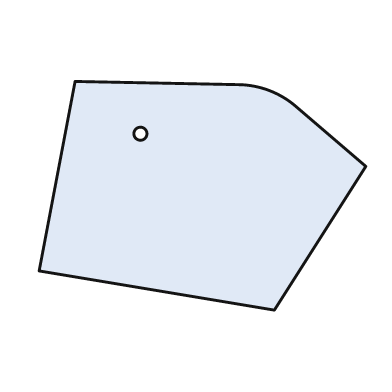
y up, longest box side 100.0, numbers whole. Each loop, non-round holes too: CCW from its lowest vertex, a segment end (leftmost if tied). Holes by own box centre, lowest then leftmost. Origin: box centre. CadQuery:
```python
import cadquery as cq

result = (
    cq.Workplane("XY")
    .moveTo(22.0, -35.0)
    .lineTo(50.0, 9.0)
    .lineTo(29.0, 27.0)
    .threePointArc((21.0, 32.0), (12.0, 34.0))
    .lineTo(-39.0, 35.0)
    .lineTo(-50.0, -23.0)
    .close()
    .moveTo(-19.0, 19.0)
    .circle(2.0)
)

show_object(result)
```